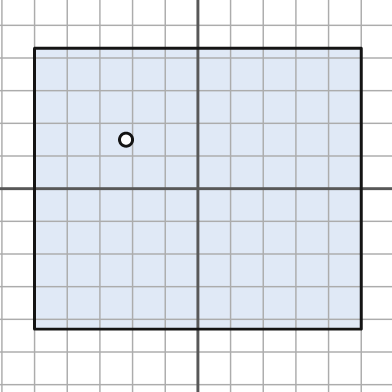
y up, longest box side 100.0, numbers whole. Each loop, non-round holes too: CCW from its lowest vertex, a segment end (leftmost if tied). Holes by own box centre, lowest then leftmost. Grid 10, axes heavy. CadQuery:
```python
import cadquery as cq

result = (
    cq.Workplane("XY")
    .moveTo(-50.0, -43.0)
    .lineTo(50.0, -43.0)
    .lineTo(50.0, 43.0)
    .lineTo(-50.0, 43.0)
    .close()
    .moveTo(-22.0, 15.0)
    .circle(2.0)
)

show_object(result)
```